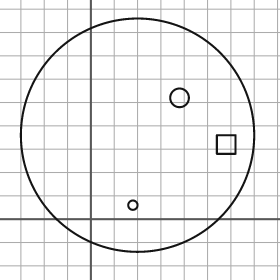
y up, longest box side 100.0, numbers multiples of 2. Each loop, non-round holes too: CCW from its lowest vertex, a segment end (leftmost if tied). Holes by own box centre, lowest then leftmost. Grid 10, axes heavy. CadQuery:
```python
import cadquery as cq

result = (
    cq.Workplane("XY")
    .moveTo(20.0, 36.0)
    .circle(50.0)
    .moveTo(18.0, 6.0)
    .circle(2.0)
    .moveTo(54.0, 28.0)
    .lineTo(62.0, 28.0)
    .lineTo(62.0, 36.0)
    .lineTo(54.0, 36.0)
    .close()
    .moveTo(38.0, 52.0)
    .circle(4.0)
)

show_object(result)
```